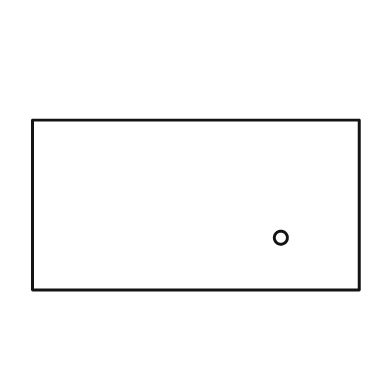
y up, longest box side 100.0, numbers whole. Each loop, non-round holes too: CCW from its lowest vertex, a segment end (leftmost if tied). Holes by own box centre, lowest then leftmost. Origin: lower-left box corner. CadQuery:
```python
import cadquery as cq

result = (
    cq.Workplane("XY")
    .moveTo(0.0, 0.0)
    .lineTo(100.0, 0.0)
    .lineTo(100.0, 52.0)
    .lineTo(0.0, 52.0)
    .close()
    .moveTo(76.0, 16.0)
    .circle(2.0)
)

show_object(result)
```